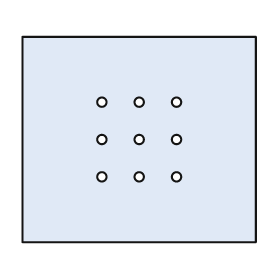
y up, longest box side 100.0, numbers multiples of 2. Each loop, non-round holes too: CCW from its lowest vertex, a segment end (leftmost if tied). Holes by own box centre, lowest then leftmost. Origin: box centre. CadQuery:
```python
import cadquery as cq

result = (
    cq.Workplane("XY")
    .moveTo(-50.0, -44.0)
    .lineTo(50.0, -44.0)
    .lineTo(50.0, 44.0)
    .lineTo(-50.0, 44.0)
    .close()
    .moveTo(-16.0, -16.0)
    .circle(2.0)
    .moveTo(0.0, -16.0)
    .circle(2.0)
    .moveTo(16.0, -16.0)
    .circle(2.0)
    .moveTo(-16.0, 0.0)
    .circle(2.0)
    .moveTo(0.0, 0.0)
    .circle(2.0)
    .moveTo(16.0, 0.0)
    .circle(2.0)
    .moveTo(-16.0, 16.0)
    .circle(2.0)
    .moveTo(0.0, 16.0)
    .circle(2.0)
    .moveTo(16.0, 16.0)
    .circle(2.0)
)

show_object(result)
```